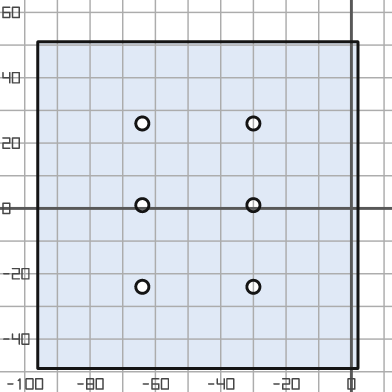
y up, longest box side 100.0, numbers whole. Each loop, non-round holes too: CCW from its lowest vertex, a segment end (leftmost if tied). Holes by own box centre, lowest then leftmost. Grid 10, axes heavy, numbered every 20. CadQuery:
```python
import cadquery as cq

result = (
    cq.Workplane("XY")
    .moveTo(-96.0, -49.0)
    .lineTo(2.0, -49.0)
    .lineTo(2.0, 51.0)
    .lineTo(-96.0, 51.0)
    .close()
    .moveTo(-64.0, -24.0)
    .circle(2.0)
    .moveTo(-30.0, -24.0)
    .circle(2.0)
    .moveTo(-64.0, 1.0)
    .circle(2.0)
    .moveTo(-30.0, 1.0)
    .circle(2.0)
    .moveTo(-64.0, 26.0)
    .circle(2.0)
    .moveTo(-30.0, 26.0)
    .circle(2.0)
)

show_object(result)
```